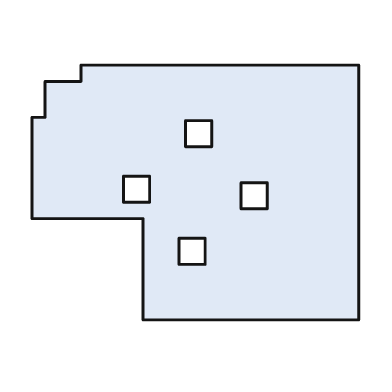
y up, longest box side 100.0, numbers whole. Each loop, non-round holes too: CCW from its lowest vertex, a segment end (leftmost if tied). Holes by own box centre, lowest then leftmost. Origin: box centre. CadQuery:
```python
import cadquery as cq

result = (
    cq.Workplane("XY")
    .moveTo(-16.0, -39.0)
    .lineTo(50.0, -39.0)
    .lineTo(50.0, 39.0)
    .lineTo(-35.0, 39.0)
    .lineTo(-35.0, 34.0)
    .lineTo(-46.0, 34.0)
    .lineTo(-46.0, 23.0)
    .lineTo(-50.0, 23.0)
    .lineTo(-50.0, -8.0)
    .lineTo(-16.0, -8.0)
    .close()
    .moveTo(-5.0, -22.0)
    .lineTo(3.0, -22.0)
    .lineTo(3.0, -14.0)
    .lineTo(-5.0, -14.0)
    .close()
    .moveTo(14.0, -5.0)
    .lineTo(22.0, -5.0)
    .lineTo(22.0, 3.0)
    .lineTo(14.0, 3.0)
    .close()
    .moveTo(-22.0, -3.0)
    .lineTo(-14.0, -3.0)
    .lineTo(-14.0, 5.0)
    .lineTo(-22.0, 5.0)
    .close()
    .moveTo(-3.0, 14.0)
    .lineTo(5.0, 14.0)
    .lineTo(5.0, 22.0)
    .lineTo(-3.0, 22.0)
    .close()
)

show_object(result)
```